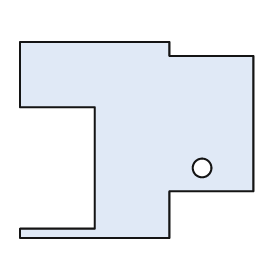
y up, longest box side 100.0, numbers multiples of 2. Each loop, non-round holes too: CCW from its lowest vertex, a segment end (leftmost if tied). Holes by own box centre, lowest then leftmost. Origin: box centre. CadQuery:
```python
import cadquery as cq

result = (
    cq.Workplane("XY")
    .moveTo(-50.0, -42.0)
    .lineTo(14.0, -42.0)
    .lineTo(14.0, -22.0)
    .lineTo(50.0, -22.0)
    .lineTo(50.0, 36.0)
    .lineTo(14.0, 36.0)
    .lineTo(14.0, 42.0)
    .lineTo(-50.0, 42.0)
    .lineTo(-50.0, 14.0)
    .lineTo(-18.0, 14.0)
    .lineTo(-18.0, -38.0)
    .lineTo(-50.0, -38.0)
    .close()
    .moveTo(28.0, -12.0)
    .circle(4.0)
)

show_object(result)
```